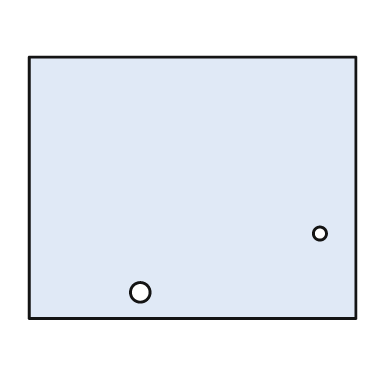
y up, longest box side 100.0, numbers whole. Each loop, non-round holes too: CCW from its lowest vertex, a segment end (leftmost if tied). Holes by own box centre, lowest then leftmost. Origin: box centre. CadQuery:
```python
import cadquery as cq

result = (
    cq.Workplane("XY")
    .moveTo(-50.0, -40.0)
    .lineTo(50.0, -40.0)
    .lineTo(50.0, 40.0)
    .lineTo(-50.0, 40.0)
    .close()
    .moveTo(-16.0, -32.0)
    .circle(3.0)
    .moveTo(39.0, -14.0)
    .circle(2.0)
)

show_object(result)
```